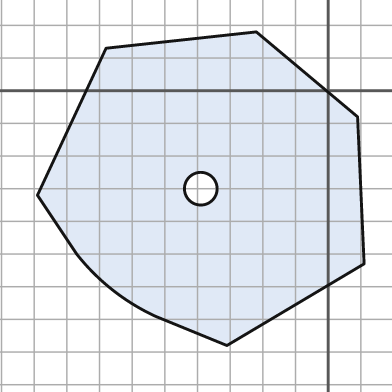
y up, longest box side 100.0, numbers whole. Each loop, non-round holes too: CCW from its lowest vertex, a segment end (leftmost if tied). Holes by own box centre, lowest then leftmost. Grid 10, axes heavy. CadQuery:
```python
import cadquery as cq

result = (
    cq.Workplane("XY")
    .moveTo(-31.0, -78.0)
    .lineTo(11.0, -53.0)
    .lineTo(9.0, -8.0)
    .lineTo(-22.0, 18.0)
    .lineTo(-68.0, 13.0)
    .lineTo(-89.0, -32.0)
    .lineTo(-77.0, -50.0)
    .threePointArc((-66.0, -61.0), (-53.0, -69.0))
    .close()
    .moveTo(-39.0, -30.0)
    .circle(5.0)
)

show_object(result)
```